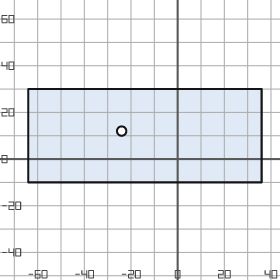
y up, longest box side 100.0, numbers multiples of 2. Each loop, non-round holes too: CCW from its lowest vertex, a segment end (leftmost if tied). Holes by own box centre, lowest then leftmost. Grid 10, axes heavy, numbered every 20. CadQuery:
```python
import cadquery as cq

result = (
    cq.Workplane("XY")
    .moveTo(-64.0, -10.0)
    .lineTo(36.0, -10.0)
    .lineTo(36.0, 30.0)
    .lineTo(-64.0, 30.0)
    .close()
    .moveTo(-24.0, 12.0)
    .circle(2.0)
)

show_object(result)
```